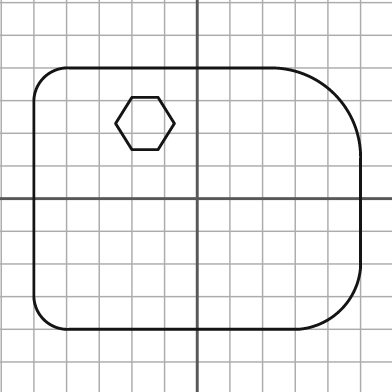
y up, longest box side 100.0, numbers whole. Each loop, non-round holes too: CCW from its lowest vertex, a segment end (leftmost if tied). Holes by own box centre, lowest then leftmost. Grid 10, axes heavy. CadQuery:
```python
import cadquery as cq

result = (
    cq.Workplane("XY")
    .moveTo(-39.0, -40.0)
    .lineTo(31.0, -40.0)
    .threePointArc((44.0, -34.0), (50.0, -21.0))
    .lineTo(50.0, 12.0)
    .threePointArc((42.0, 32.0), (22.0, 40.0))
    .lineTo(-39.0, 40.0)
    .threePointArc((-47.0, 37.0), (-50.0, 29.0))
    .lineTo(-50.0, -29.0)
    .threePointArc((-47.0, -37.0), (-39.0, -40.0))
    .close()
    .moveTo(-20.0, 15.0)
    .lineTo(-12.0, 15.0)
    .lineTo(-7.0, 23.0)
    .lineTo(-12.0, 31.0)
    .lineTo(-20.0, 31.0)
    .lineTo(-25.0, 23.0)
    .close()
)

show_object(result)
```